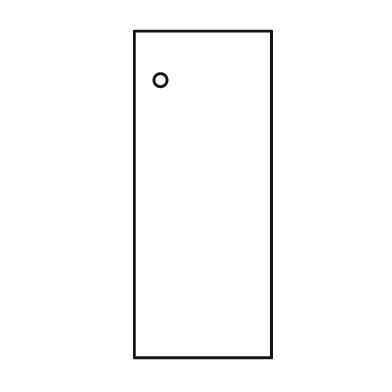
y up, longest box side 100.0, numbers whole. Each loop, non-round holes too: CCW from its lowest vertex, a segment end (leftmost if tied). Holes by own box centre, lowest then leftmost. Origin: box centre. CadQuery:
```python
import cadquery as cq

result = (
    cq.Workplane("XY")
    .moveTo(-21.0, -50.0)
    .lineTo(21.0, -50.0)
    .lineTo(21.0, 50.0)
    .lineTo(-21.0, 50.0)
    .close()
    .moveTo(-13.0, 35.0)
    .circle(2.0)
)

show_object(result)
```